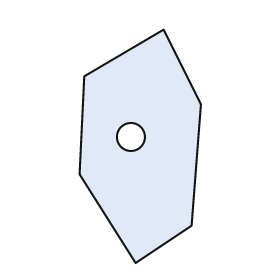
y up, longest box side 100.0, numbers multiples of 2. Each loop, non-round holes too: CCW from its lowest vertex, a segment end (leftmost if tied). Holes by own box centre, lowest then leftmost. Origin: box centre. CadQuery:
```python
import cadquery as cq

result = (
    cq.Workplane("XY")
    .moveTo(-2.0, -50.0)
    .lineTo(22.0, -34.0)
    .lineTo(26.0, 18.0)
    .lineTo(10.0, 50.0)
    .lineTo(-24.0, 30.0)
    .lineTo(-26.0, -12.0)
    .close()
    .moveTo(-4.0, 4.0)
    .circle(6.0)
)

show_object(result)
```